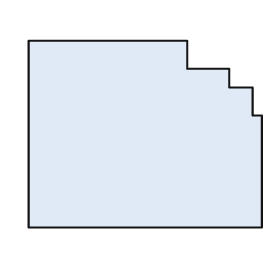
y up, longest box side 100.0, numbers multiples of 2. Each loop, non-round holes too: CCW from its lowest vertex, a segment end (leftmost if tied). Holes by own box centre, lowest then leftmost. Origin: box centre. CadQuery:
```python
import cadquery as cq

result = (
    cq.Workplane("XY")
    .moveTo(-50.0, -40.0)
    .lineTo(50.0, -40.0)
    .lineTo(50.0, 8.0)
    .lineTo(46.0, 8.0)
    .lineTo(46.0, 20.0)
    .lineTo(36.0, 20.0)
    .lineTo(36.0, 28.0)
    .lineTo(18.0, 28.0)
    .lineTo(18.0, 40.0)
    .lineTo(-50.0, 40.0)
    .close()
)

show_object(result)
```